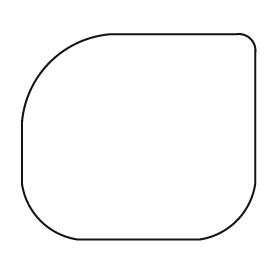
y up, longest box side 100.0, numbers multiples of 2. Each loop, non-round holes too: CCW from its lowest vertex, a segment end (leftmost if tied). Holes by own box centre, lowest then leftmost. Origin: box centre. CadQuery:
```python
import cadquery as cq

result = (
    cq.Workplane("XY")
    .moveTo(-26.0, -44.0)
    .lineTo(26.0, -44.0)
    .threePointArc((42.0, -36.0), (50.0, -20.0))
    .lineTo(50.0, 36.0)
    .threePointArc((48.0, 42.0), (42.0, 44.0))
    .lineTo(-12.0, 44.0)
    .threePointArc((-38.0, 32.0), (-50.0, 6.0))
    .lineTo(-50.0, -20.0)
    .threePointArc((-42.0, -36.0), (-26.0, -44.0))
    .close()
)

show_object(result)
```